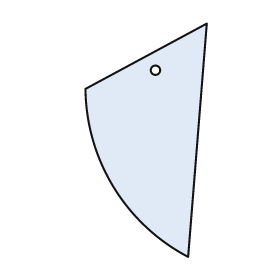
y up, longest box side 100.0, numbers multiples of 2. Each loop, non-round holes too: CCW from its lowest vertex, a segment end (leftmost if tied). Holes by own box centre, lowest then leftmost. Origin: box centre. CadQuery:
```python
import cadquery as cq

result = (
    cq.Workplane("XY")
    .moveTo(18.0, -50.0)
    .lineTo(26.0, 50.0)
    .lineTo(-26.0, 22.0)
    .threePointArc((-14.0, -20.0), (18.0, -50.0))
    .close()
    .moveTo(4.0, 30.0)
    .circle(2.0)
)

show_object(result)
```